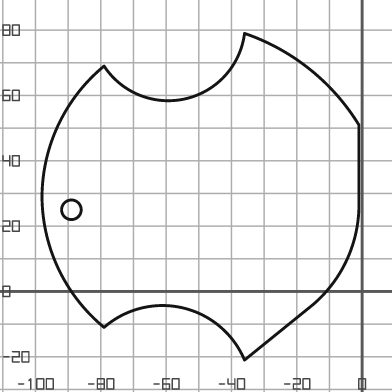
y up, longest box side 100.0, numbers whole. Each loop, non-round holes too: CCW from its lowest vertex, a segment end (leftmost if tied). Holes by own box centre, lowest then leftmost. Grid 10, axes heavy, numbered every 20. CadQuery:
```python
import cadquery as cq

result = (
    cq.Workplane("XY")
    .moveTo(-36.0, -21.0)
    .lineTo(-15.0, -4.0)
    .threePointArc((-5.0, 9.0), (-1.0, 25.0))
    .lineTo(-1.0, 51.0)
    .threePointArc((-16.0, 68.0), (-36.0, 79.0))
    .threePointArc((-54.0, 59.0), (-79.0, 69.0))
    .threePointArc((-93.0, 51.0), (-98.0, 29.0))
    .threePointArc((-93.0, 7.0), (-79.0, -11.0))
    .threePointArc((-55.0, -5.0), (-36.0, -21.0))
    .close()
    .moveTo(-89.0, 25.0)
    .circle(3.0)
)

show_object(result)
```